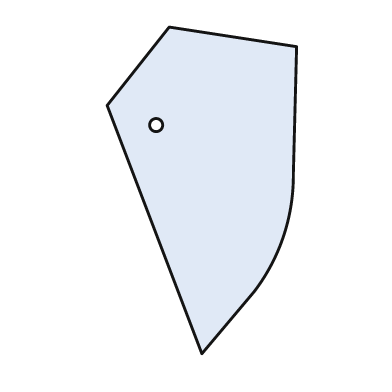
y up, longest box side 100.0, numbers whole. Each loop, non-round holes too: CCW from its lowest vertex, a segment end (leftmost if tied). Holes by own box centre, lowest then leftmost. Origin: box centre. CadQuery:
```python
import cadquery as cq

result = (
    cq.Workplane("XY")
    .moveTo(0.0, -50.0)
    .lineTo(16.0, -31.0)
    .threePointArc((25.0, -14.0), (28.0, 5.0))
    .lineTo(29.0, 44.0)
    .lineTo(-10.0, 50.0)
    .lineTo(-29.0, 26.0)
    .close()
    .moveTo(-14.0, 20.0)
    .circle(2.0)
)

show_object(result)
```